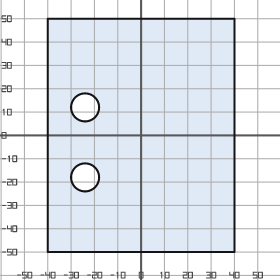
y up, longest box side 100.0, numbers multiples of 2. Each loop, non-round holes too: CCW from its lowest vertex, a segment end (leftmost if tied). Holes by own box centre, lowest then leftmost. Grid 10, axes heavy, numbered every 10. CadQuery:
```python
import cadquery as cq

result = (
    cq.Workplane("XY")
    .moveTo(-40.0, -50.0)
    .lineTo(40.0, -50.0)
    .lineTo(40.0, 50.0)
    .lineTo(-40.0, 50.0)
    .close()
    .moveTo(-24.0, -18.0)
    .circle(6.0)
    .moveTo(-24.0, 12.0)
    .circle(6.0)
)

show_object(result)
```